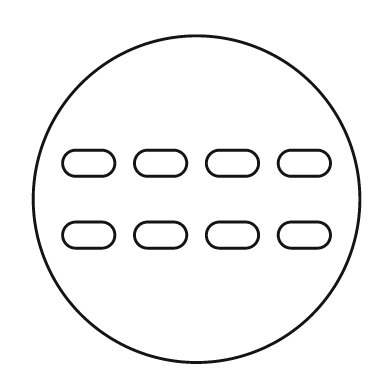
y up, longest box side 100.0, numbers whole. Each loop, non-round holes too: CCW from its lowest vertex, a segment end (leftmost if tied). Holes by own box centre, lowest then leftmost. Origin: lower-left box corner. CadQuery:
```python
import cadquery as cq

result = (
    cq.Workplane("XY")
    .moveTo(50.0, 50.0)
    .circle(50.0)
    .moveTo(13.0, 35.0)
    .lineTo(21.0, 35.0)
    .threePointArc((25.0, 39.0), (21.0, 43.0))
    .lineTo(13.0, 43.0)
    .threePointArc((9.0, 39.0), (13.0, 35.0))
    .close()
    .moveTo(35.0, 35.0)
    .lineTo(43.0, 35.0)
    .threePointArc((47.0, 39.0), (43.0, 43.0))
    .lineTo(35.0, 43.0)
    .threePointArc((31.0, 39.0), (35.0, 35.0))
    .close()
    .moveTo(57.0, 35.0)
    .lineTo(65.0, 35.0)
    .threePointArc((69.0, 39.0), (65.0, 43.0))
    .lineTo(57.0, 43.0)
    .threePointArc((53.0, 39.0), (57.0, 35.0))
    .close()
    .moveTo(79.0, 35.0)
    .lineTo(87.0, 35.0)
    .threePointArc((91.0, 39.0), (87.0, 43.0))
    .lineTo(79.0, 43.0)
    .threePointArc((75.0, 39.0), (79.0, 35.0))
    .close()
    .moveTo(13.0, 57.0)
    .lineTo(21.0, 57.0)
    .threePointArc((25.0, 61.0), (21.0, 65.0))
    .lineTo(13.0, 65.0)
    .threePointArc((9.0, 61.0), (13.0, 57.0))
    .close()
    .moveTo(35.0, 57.0)
    .lineTo(43.0, 57.0)
    .threePointArc((47.0, 61.0), (43.0, 65.0))
    .lineTo(35.0, 65.0)
    .threePointArc((31.0, 61.0), (35.0, 57.0))
    .close()
    .moveTo(57.0, 57.0)
    .lineTo(65.0, 57.0)
    .threePointArc((69.0, 61.0), (65.0, 65.0))
    .lineTo(57.0, 65.0)
    .threePointArc((53.0, 61.0), (57.0, 57.0))
    .close()
    .moveTo(79.0, 57.0)
    .lineTo(87.0, 57.0)
    .threePointArc((91.0, 61.0), (87.0, 65.0))
    .lineTo(79.0, 65.0)
    .threePointArc((75.0, 61.0), (79.0, 57.0))
    .close()
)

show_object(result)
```